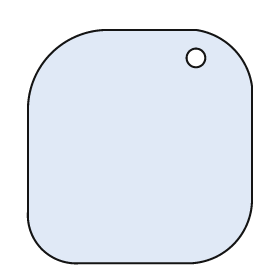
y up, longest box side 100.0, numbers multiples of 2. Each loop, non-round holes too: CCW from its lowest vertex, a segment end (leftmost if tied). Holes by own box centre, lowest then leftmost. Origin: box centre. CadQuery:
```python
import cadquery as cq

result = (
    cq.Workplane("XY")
    .moveTo(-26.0, -50.0)
    .lineTo(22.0, -50.0)
    .threePointArc((40.0, -42.0), (48.0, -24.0))
    .lineTo(48.0, 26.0)
    .threePointArc((40.0, 42.0), (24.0, 50.0))
    .lineTo(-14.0, 50.0)
    .threePointArc((-38.0, 40.0), (-48.0, 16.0))
    .lineTo(-48.0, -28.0)
    .threePointArc((-42.0, -44.0), (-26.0, -50.0))
    .close()
    .moveTo(24.0, 38.0)
    .circle(4.0)
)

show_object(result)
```